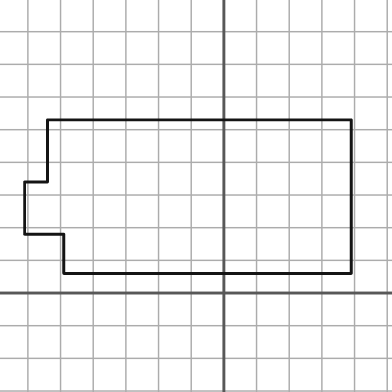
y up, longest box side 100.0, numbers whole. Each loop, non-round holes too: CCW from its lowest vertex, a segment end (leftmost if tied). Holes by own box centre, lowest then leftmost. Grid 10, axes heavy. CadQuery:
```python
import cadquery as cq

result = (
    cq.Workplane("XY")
    .moveTo(-49.0, 6.0)
    .lineTo(39.0, 6.0)
    .lineTo(39.0, 53.0)
    .lineTo(-54.0, 53.0)
    .lineTo(-54.0, 34.0)
    .lineTo(-61.0, 34.0)
    .lineTo(-61.0, 18.0)
    .lineTo(-49.0, 18.0)
    .close()
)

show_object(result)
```